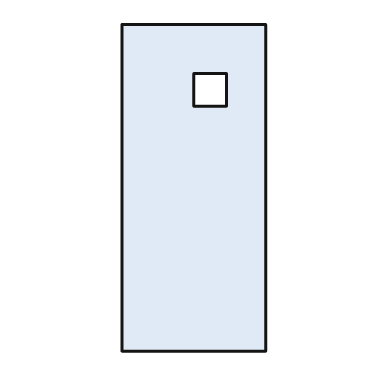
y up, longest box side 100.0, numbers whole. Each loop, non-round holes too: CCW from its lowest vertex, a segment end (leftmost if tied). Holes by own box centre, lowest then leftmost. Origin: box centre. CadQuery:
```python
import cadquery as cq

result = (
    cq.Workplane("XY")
    .moveTo(-22.0, -50.0)
    .lineTo(22.0, -50.0)
    .lineTo(22.0, 50.0)
    .lineTo(-22.0, 50.0)
    .close()
    .moveTo(0.0, 25.0)
    .lineTo(10.0, 25.0)
    .lineTo(10.0, 35.0)
    .lineTo(0.0, 35.0)
    .close()
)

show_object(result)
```